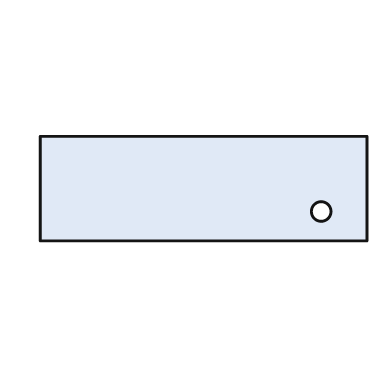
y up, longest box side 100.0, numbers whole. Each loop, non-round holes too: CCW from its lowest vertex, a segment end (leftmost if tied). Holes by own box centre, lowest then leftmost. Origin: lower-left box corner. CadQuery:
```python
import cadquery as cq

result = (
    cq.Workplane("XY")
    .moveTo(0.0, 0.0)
    .lineTo(100.0, 0.0)
    .lineTo(100.0, 32.0)
    .lineTo(0.0, 32.0)
    .close()
    .moveTo(86.0, 9.0)
    .circle(3.0)
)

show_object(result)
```